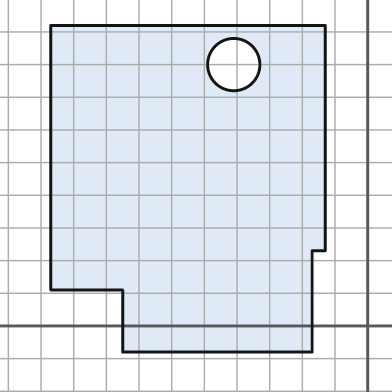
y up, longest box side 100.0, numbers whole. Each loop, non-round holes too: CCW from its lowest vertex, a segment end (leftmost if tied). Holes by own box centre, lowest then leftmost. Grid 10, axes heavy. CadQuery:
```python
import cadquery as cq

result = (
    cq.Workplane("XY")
    .moveTo(-75.0, -8.0)
    .lineTo(-17.0, -8.0)
    .lineTo(-17.0, 23.0)
    .lineTo(-13.0, 23.0)
    .lineTo(-13.0, 92.0)
    .lineTo(-97.0, 92.0)
    .lineTo(-97.0, 11.0)
    .lineTo(-75.0, 11.0)
    .close()
    .moveTo(-41.0, 80.0)
    .circle(8.0)
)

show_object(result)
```